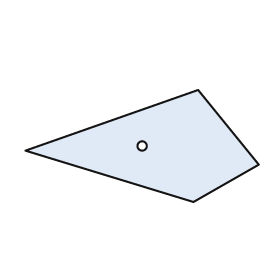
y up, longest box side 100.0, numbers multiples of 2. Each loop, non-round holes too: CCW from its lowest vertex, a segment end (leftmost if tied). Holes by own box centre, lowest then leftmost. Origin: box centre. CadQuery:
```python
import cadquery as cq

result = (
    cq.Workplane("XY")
    .moveTo(22.0, -24.0)
    .lineTo(50.0, -8.0)
    .lineTo(24.0, 24.0)
    .lineTo(-50.0, -2.0)
    .close()
    .moveTo(0.0, 0.0)
    .circle(2.0)
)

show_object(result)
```